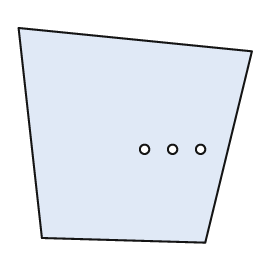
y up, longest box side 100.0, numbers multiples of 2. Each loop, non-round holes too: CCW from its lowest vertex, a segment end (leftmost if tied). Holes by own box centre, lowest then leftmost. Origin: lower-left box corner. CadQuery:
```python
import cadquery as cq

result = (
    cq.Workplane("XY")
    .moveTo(80.0, 0.0)
    .lineTo(100.0, 82.0)
    .lineTo(0.0, 92.0)
    .lineTo(10.0, 2.0)
    .close()
    .moveTo(54.0, 40.0)
    .circle(2.0)
    .moveTo(66.0, 40.0)
    .circle(2.0)
    .moveTo(78.0, 40.0)
    .circle(2.0)
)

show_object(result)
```